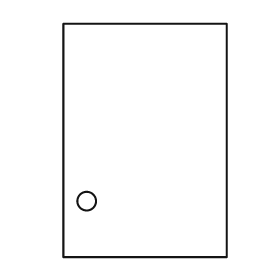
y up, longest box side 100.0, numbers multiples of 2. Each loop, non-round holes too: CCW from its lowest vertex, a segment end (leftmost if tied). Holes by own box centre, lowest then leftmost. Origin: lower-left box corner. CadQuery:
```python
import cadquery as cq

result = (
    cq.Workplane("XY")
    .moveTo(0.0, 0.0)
    .lineTo(70.0, 0.0)
    .lineTo(70.0, 100.0)
    .lineTo(0.0, 100.0)
    .close()
    .moveTo(10.0, 24.0)
    .circle(4.0)
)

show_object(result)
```